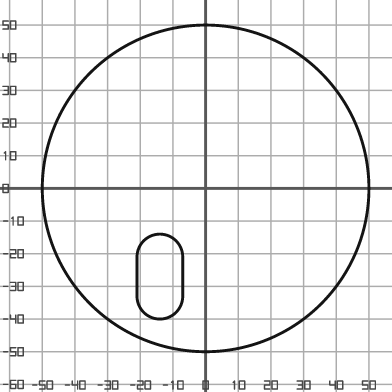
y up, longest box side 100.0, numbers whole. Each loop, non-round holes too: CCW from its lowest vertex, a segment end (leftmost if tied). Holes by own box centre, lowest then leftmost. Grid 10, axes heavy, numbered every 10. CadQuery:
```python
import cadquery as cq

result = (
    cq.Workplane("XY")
    .moveTo(0.0, 0.0)
    .circle(50.0)
    .moveTo(-21.0, -33.0)
    .threePointArc((-14.0, -40.0), (-7.0, -33.0))
    .lineTo(-7.0, -21.0)
    .threePointArc((-14.0, -14.0), (-21.0, -21.0))
    .close()
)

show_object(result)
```